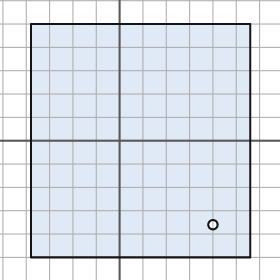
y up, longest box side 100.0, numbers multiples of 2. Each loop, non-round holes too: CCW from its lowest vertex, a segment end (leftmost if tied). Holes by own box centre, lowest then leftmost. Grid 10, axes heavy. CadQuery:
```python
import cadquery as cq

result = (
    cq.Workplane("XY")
    .moveTo(-38.0, -50.0)
    .lineTo(56.0, -50.0)
    .lineTo(56.0, 50.0)
    .lineTo(-38.0, 50.0)
    .close()
    .moveTo(40.0, -36.0)
    .circle(2.0)
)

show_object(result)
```